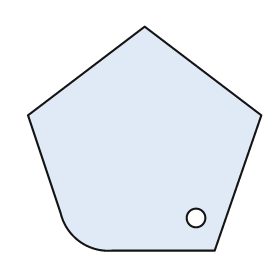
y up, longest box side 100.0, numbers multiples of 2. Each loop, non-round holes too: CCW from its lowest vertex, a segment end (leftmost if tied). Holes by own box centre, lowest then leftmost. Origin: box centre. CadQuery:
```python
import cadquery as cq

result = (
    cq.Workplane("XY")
    .moveTo(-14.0, -48.0)
    .lineTo(30.0, -48.0)
    .lineTo(50.0, 10.0)
    .lineTo(0.0, 48.0)
    .lineTo(-50.0, 10.0)
    .lineTo(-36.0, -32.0)
    .threePointArc((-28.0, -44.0), (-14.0, -48.0))
    .close()
    .moveTo(22.0, -34.0)
    .circle(4.0)
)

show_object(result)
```